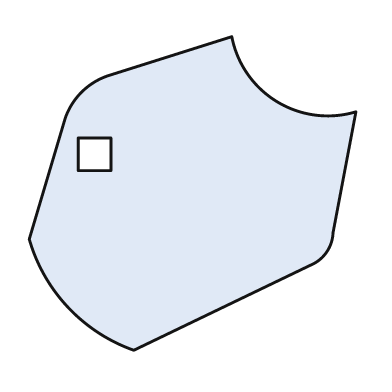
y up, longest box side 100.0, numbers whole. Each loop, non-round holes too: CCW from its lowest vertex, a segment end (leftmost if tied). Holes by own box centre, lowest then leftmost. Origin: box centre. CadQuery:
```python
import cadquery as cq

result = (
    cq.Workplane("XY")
    .moveTo(-18.0, -48.0)
    .lineTo(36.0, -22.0)
    .threePointArc((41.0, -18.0), (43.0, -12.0))
    .lineTo(50.0, 25.0)
    .threePointArc((26.0, 28.0), (12.0, 48.0))
    .lineTo(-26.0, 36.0)
    .threePointArc((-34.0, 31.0), (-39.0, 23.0))
    .lineTo(-50.0, -14.0)
    .threePointArc((-38.0, -35.0), (-18.0, -48.0))
    .close()
    .moveTo(-35.0, 7.0)
    .lineTo(-25.0, 7.0)
    .lineTo(-25.0, 17.0)
    .lineTo(-35.0, 17.0)
    .close()
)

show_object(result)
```